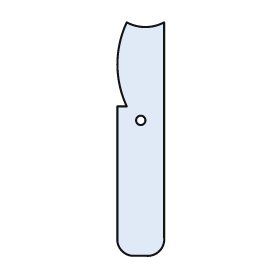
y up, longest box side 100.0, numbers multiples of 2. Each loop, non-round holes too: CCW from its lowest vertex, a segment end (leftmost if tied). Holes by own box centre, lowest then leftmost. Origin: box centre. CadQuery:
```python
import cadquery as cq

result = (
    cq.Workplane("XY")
    .moveTo(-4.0, -50.0)
    .lineTo(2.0, -50.0)
    .threePointArc((8.0, -48.0), (10.0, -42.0))
    .lineTo(10.0, 50.0)
    .threePointArc((2.0, 48.0), (-6.0, 50.0))
    .threePointArc((-10.0, 32.0), (-6.0, 14.0))
    .lineTo(-10.0, 14.0)
    .lineTo(-10.0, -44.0)
    .threePointArc((-8.0, -48.0), (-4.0, -50.0))
    .close()
    .moveTo(0.0, 8.0)
    .circle(2.0)
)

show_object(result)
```